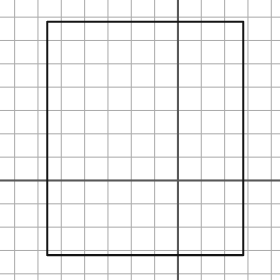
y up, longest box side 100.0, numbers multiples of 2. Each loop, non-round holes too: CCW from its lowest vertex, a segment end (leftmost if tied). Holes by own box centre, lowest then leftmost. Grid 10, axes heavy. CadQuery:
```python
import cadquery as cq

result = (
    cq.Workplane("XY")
    .moveTo(-56.0, -32.0)
    .lineTo(28.0, -32.0)
    .lineTo(28.0, 68.0)
    .lineTo(-56.0, 68.0)
    .close()
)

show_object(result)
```